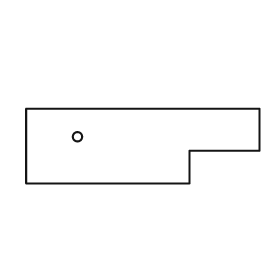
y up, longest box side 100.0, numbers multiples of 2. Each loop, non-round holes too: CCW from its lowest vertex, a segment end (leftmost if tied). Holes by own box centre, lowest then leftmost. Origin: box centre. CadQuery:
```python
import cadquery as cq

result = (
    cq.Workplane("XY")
    .moveTo(-50.0, -16.0)
    .lineTo(20.0, -16.0)
    .lineTo(20.0, -2.0)
    .lineTo(50.0, -2.0)
    .lineTo(50.0, 16.0)
    .lineTo(-50.0, 16.0)
    .close()
    .moveTo(-28.0, 4.0)
    .circle(2.0)
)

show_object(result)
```